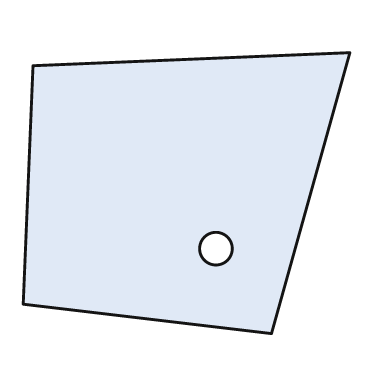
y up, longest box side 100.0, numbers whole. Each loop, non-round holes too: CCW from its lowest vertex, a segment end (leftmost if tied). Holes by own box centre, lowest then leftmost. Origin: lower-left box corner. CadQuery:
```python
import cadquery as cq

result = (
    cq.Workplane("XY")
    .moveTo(76.0, 0.0)
    .lineTo(100.0, 86.0)
    .lineTo(3.0, 82.0)
    .lineTo(0.0, 9.0)
    .close()
    .moveTo(59.0, 26.0)
    .circle(5.0)
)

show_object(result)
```